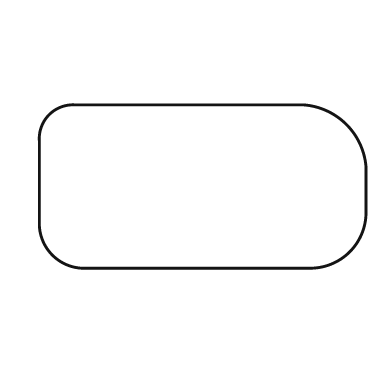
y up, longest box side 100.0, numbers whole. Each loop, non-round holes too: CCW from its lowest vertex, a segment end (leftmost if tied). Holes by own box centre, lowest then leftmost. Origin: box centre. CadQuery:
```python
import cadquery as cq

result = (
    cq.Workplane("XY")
    .moveTo(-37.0, -25.0)
    .lineTo(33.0, -25.0)
    .threePointArc((45.0, -20.0), (50.0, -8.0))
    .lineTo(50.0, 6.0)
    .threePointArc((44.0, 19.0), (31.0, 25.0))
    .lineTo(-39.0, 25.0)
    .threePointArc((-47.0, 22.0), (-50.0, 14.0))
    .lineTo(-50.0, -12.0)
    .threePointArc((-46.0, -21.0), (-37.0, -25.0))
    .close()
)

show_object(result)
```